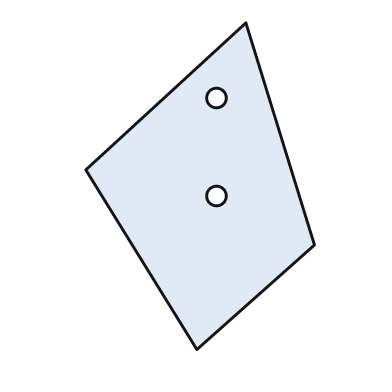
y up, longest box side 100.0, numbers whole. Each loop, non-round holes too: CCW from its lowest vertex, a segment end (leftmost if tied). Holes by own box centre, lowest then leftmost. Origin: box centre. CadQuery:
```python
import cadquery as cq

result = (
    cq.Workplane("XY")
    .moveTo(-1.0, -50.0)
    .lineTo(35.0, -18.0)
    .lineTo(14.0, 50.0)
    .lineTo(-35.0, 5.0)
    .close()
    .moveTo(5.0, -3.0)
    .circle(3.0)
    .moveTo(5.0, 27.0)
    .circle(3.0)
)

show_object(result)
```